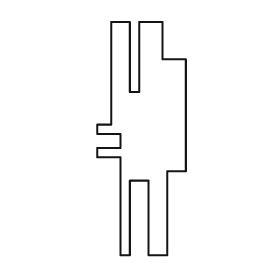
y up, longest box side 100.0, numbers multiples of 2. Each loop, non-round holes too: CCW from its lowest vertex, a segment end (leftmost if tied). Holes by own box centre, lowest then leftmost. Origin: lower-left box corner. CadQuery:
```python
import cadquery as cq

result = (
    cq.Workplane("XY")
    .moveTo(10.0, 0.0)
    .lineTo(14.0, 0.0)
    .lineTo(14.0, 32.0)
    .lineTo(22.0, 32.0)
    .lineTo(22.0, 0.0)
    .lineTo(30.0, 0.0)
    .lineTo(30.0, 36.0)
    .lineTo(38.0, 36.0)
    .lineTo(38.0, 84.0)
    .lineTo(28.0, 84.0)
    .lineTo(28.0, 100.0)
    .lineTo(18.0, 100.0)
    .lineTo(18.0, 70.0)
    .lineTo(14.0, 70.0)
    .lineTo(14.0, 100.0)
    .lineTo(6.0, 100.0)
    .lineTo(6.0, 56.0)
    .lineTo(0.0, 56.0)
    .lineTo(0.0, 52.0)
    .lineTo(10.0, 52.0)
    .lineTo(10.0, 46.0)
    .lineTo(0.0, 46.0)
    .lineTo(0.0, 42.0)
    .lineTo(10.0, 42.0)
    .close()
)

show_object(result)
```